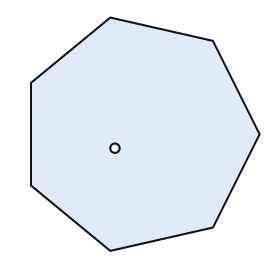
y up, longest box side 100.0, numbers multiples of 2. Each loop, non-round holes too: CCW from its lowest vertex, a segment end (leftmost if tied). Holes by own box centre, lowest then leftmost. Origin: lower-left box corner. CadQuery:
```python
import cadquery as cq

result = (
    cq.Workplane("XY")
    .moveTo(34.0, 0.0)
    .lineTo(78.0, 10.0)
    .lineTo(98.0, 50.0)
    .lineTo(78.0, 90.0)
    .lineTo(34.0, 100.0)
    .lineTo(0.0, 72.0)
    .lineTo(0.0, 28.0)
    .close()
    .moveTo(36.0, 44.0)
    .circle(2.0)
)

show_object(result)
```